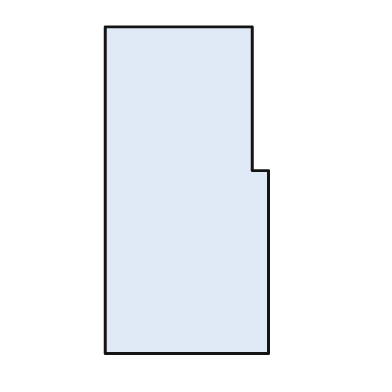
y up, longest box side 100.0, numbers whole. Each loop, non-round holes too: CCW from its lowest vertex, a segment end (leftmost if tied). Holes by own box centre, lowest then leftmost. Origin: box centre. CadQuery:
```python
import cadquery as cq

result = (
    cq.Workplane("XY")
    .moveTo(-25.0, -50.0)
    .lineTo(25.0, -50.0)
    .lineTo(25.0, 6.0)
    .lineTo(20.0, 6.0)
    .lineTo(20.0, 50.0)
    .lineTo(-25.0, 50.0)
    .close()
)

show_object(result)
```